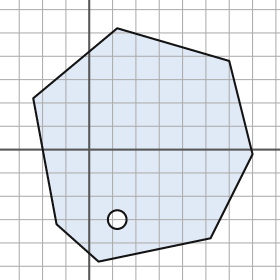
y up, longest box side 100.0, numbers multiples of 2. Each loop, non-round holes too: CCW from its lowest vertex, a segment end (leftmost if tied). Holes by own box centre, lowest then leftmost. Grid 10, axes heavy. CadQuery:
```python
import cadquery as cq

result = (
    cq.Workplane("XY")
    .moveTo(4.0, -48.0)
    .lineTo(52.0, -38.0)
    .lineTo(70.0, -2.0)
    .lineTo(60.0, 38.0)
    .lineTo(12.0, 52.0)
    .lineTo(-24.0, 22.0)
    .lineTo(-14.0, -32.0)
    .close()
    .moveTo(12.0, -30.0)
    .circle(4.0)
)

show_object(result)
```